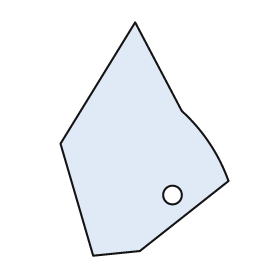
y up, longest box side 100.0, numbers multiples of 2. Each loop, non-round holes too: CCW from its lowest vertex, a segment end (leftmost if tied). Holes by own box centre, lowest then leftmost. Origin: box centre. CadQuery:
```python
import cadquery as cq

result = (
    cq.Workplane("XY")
    .moveTo(-22.0, -50.0)
    .lineTo(-2.0, -48.0)
    .lineTo(36.0, -18.0)
    .threePointArc((28.0, -2.0), (16.0, 12.0))
    .lineTo(-4.0, 50.0)
    .lineTo(-36.0, -2.0)
    .close()
    .moveTo(12.0, -24.0)
    .circle(4.0)
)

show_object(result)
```